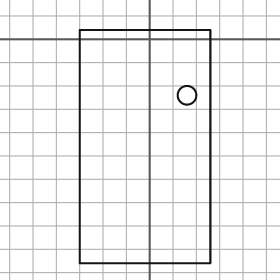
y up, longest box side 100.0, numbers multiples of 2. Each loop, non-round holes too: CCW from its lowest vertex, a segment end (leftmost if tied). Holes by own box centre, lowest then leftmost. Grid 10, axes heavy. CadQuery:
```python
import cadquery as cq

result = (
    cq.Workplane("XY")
    .moveTo(-30.0, -96.0)
    .lineTo(26.0, -96.0)
    .lineTo(26.0, 4.0)
    .lineTo(-30.0, 4.0)
    .close()
    .moveTo(16.0, -24.0)
    .circle(4.0)
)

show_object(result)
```